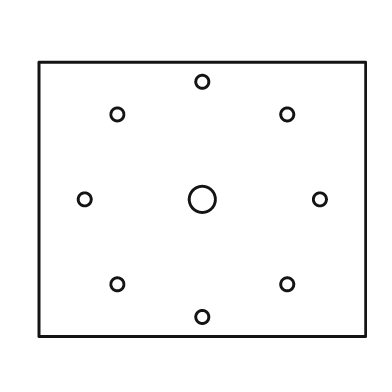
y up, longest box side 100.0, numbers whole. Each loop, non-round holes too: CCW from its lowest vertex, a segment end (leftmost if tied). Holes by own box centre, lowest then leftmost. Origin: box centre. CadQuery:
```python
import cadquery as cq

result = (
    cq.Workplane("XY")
    .moveTo(-50.0, -42.0)
    .lineTo(50.0, -42.0)
    .lineTo(50.0, 42.0)
    .lineTo(-50.0, 42.0)
    .close()
    .moveTo(0.0, -36.0)
    .circle(2.0)
    .moveTo(-26.0, -26.0)
    .circle(2.0)
    .moveTo(26.0, -26.0)
    .circle(2.0)
    .moveTo(-36.0, 0.0)
    .circle(2.0)
    .moveTo(0.0, 0.0)
    .circle(4.0)
    .moveTo(36.0, 0.0)
    .circle(2.0)
    .moveTo(-26.0, 26.0)
    .circle(2.0)
    .moveTo(26.0, 26.0)
    .circle(2.0)
    .moveTo(0.0, 36.0)
    .circle(2.0)
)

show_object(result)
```